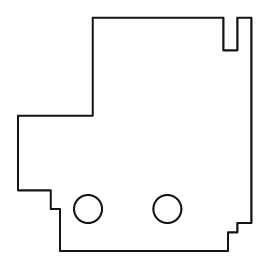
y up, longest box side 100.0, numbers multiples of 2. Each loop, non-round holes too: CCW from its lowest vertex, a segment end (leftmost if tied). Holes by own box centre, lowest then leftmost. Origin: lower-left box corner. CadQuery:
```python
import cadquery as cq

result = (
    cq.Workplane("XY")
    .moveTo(18.0, 0.0)
    .lineTo(90.0, 0.0)
    .lineTo(90.0, 8.0)
    .lineTo(94.0, 8.0)
    .lineTo(94.0, 12.0)
    .lineTo(100.0, 12.0)
    .lineTo(100.0, 100.0)
    .lineTo(94.0, 100.0)
    .lineTo(94.0, 86.0)
    .lineTo(88.0, 86.0)
    .lineTo(88.0, 100.0)
    .lineTo(32.0, 100.0)
    .lineTo(32.0, 58.0)
    .lineTo(0.0, 58.0)
    .lineTo(0.0, 26.0)
    .lineTo(14.0, 26.0)
    .lineTo(14.0, 18.0)
    .lineTo(18.0, 18.0)
    .close()
    .moveTo(30.0, 18.0)
    .circle(6.0)
    .moveTo(64.0, 18.0)
    .circle(6.0)
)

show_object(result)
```